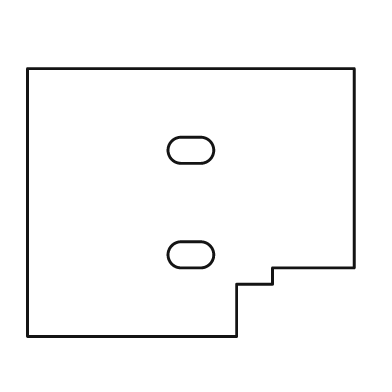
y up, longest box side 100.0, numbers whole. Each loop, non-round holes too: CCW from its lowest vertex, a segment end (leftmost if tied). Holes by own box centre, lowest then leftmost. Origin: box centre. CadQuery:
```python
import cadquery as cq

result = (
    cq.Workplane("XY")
    .moveTo(-50.0, -41.0)
    .lineTo(14.0, -41.0)
    .lineTo(14.0, -25.0)
    .lineTo(25.0, -25.0)
    .lineTo(25.0, -20.0)
    .lineTo(50.0, -20.0)
    .lineTo(50.0, 41.0)
    .lineTo(-50.0, 41.0)
    .close()
    .moveTo(-3.0, -20.0)
    .lineTo(3.0, -20.0)
    .threePointArc((7.0, -16.0), (3.0, -12.0))
    .lineTo(-3.0, -12.0)
    .threePointArc((-7.0, -16.0), (-3.0, -20.0))
    .close()
    .moveTo(-3.0, 12.0)
    .lineTo(3.0, 12.0)
    .threePointArc((7.0, 16.0), (3.0, 20.0))
    .lineTo(-3.0, 20.0)
    .threePointArc((-7.0, 16.0), (-3.0, 12.0))
    .close()
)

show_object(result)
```